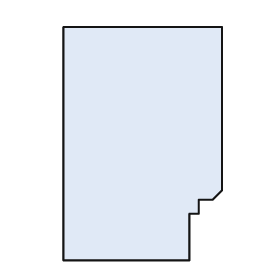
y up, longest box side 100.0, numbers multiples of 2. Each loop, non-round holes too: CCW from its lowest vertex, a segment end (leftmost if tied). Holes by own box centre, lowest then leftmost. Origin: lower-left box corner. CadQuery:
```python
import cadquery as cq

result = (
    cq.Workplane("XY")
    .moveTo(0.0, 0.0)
    .lineTo(54.0, 0.0)
    .lineTo(54.0, 20.0)
    .lineTo(58.0, 20.0)
    .lineTo(58.0, 26.0)
    .lineTo(64.0, 26.0)
    .lineTo(68.0, 30.0)
    .lineTo(68.0, 100.0)
    .lineTo(0.0, 100.0)
    .close()
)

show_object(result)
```